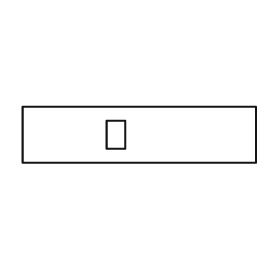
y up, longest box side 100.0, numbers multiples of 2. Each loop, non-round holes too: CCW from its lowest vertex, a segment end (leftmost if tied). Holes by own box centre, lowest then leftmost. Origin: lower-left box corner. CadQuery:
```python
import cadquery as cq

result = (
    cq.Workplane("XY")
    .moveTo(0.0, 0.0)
    .lineTo(100.0, 0.0)
    .lineTo(100.0, 24.0)
    .lineTo(0.0, 24.0)
    .close()
    .moveTo(36.0, 6.0)
    .lineTo(44.0, 6.0)
    .lineTo(44.0, 18.0)
    .lineTo(36.0, 18.0)
    .close()
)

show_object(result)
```